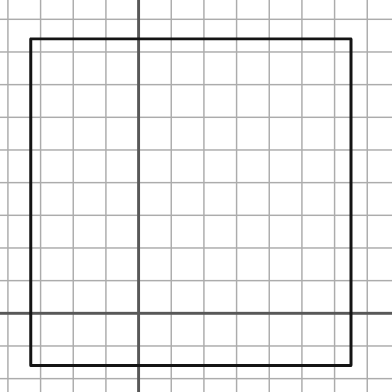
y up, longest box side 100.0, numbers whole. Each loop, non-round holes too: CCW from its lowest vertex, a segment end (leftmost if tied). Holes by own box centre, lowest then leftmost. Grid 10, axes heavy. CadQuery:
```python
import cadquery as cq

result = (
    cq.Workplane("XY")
    .moveTo(-33.0, -16.0)
    .lineTo(65.0, -16.0)
    .lineTo(65.0, 84.0)
    .lineTo(-33.0, 84.0)
    .close()
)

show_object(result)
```